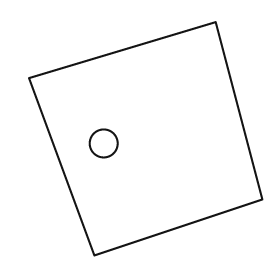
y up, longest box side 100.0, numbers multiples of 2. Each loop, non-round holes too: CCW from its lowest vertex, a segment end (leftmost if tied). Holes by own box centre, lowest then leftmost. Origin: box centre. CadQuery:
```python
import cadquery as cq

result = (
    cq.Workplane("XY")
    .moveTo(-22.0, -50.0)
    .lineTo(50.0, -26.0)
    .lineTo(30.0, 50.0)
    .lineTo(-50.0, 26.0)
    .close()
    .moveTo(-18.0, -2.0)
    .circle(6.0)
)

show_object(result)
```